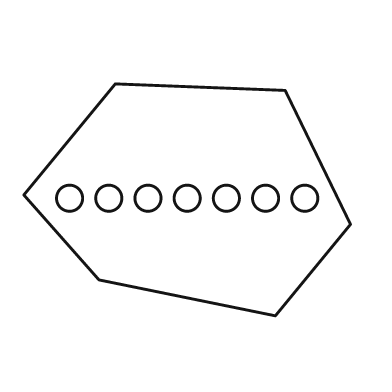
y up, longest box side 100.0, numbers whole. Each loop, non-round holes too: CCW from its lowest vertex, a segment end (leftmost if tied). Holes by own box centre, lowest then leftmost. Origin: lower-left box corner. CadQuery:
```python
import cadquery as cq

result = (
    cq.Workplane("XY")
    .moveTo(77.0, 0.0)
    .lineTo(100.0, 28.0)
    .lineTo(80.0, 69.0)
    .lineTo(28.0, 71.0)
    .lineTo(0.0, 37.0)
    .lineTo(23.0, 11.0)
    .close()
    .moveTo(14.0, 36.0)
    .circle(4.0)
    .moveTo(26.0, 36.0)
    .circle(4.0)
    .moveTo(38.0, 36.0)
    .circle(4.0)
    .moveTo(50.0, 36.0)
    .circle(4.0)
    .moveTo(62.0, 36.0)
    .circle(4.0)
    .moveTo(74.0, 36.0)
    .circle(4.0)
    .moveTo(86.0, 36.0)
    .circle(4.0)
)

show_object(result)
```